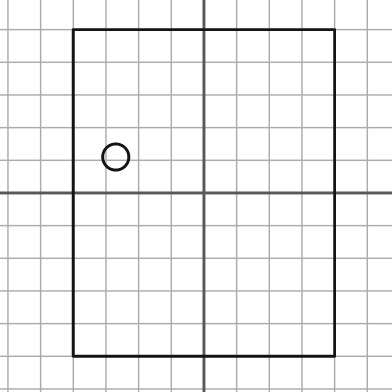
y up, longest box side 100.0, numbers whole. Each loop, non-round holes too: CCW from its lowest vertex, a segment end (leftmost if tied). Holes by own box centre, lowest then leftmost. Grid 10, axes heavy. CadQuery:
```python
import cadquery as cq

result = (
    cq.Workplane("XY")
    .moveTo(-40.0, -50.0)
    .lineTo(40.0, -50.0)
    .lineTo(40.0, 50.0)
    .lineTo(-40.0, 50.0)
    .close()
    .moveTo(-27.0, 11.0)
    .circle(4.0)
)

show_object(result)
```